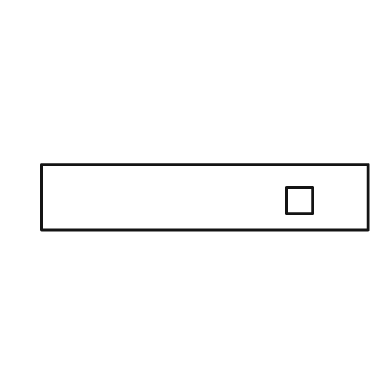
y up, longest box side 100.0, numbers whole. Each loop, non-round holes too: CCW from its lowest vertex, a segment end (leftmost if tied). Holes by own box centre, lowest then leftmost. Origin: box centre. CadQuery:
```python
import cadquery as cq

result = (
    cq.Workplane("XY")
    .moveTo(-50.0, -10.0)
    .lineTo(50.0, -10.0)
    .lineTo(50.0, 10.0)
    .lineTo(-50.0, 10.0)
    .close()
    .moveTo(25.0, -5.0)
    .lineTo(33.0, -5.0)
    .lineTo(33.0, 3.0)
    .lineTo(25.0, 3.0)
    .close()
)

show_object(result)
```